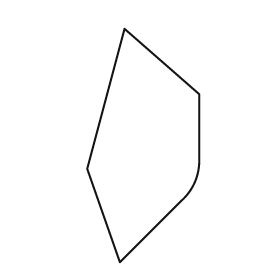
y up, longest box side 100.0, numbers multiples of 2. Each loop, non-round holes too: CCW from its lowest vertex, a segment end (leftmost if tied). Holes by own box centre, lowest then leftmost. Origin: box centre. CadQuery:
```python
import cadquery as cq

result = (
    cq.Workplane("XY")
    .moveTo(-10.0, -50.0)
    .lineTo(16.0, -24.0)
    .threePointArc((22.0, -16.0), (24.0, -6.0))
    .lineTo(24.0, 22.0)
    .lineTo(-8.0, 50.0)
    .lineTo(-24.0, -10.0)
    .close()
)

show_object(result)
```